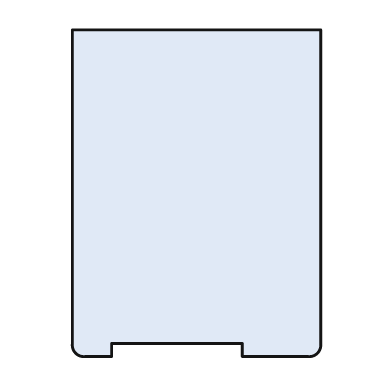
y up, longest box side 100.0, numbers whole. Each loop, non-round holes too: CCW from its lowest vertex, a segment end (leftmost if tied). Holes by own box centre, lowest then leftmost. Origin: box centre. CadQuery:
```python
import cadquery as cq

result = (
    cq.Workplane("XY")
    .moveTo(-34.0, -50.0)
    .lineTo(-26.0, -50.0)
    .lineTo(-26.0, -46.0)
    .lineTo(14.0, -46.0)
    .lineTo(14.0, -50.0)
    .lineTo(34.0, -50.0)
    .threePointArc((37.0, -49.0), (38.0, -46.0))
    .lineTo(38.0, 50.0)
    .lineTo(-38.0, 50.0)
    .lineTo(-38.0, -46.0)
    .threePointArc((-37.0, -49.0), (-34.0, -50.0))
    .close()
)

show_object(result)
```